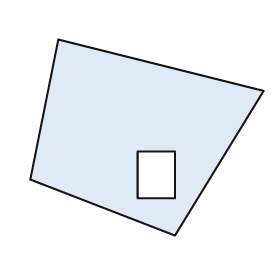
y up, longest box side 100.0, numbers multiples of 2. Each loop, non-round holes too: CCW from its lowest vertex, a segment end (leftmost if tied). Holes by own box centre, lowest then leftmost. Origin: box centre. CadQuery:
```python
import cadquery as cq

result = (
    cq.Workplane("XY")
    .moveTo(12.0, -42.0)
    .lineTo(50.0, 20.0)
    .lineTo(-38.0, 42.0)
    .lineTo(-50.0, -18.0)
    .close()
    .moveTo(-4.0, -26.0)
    .lineTo(12.0, -26.0)
    .lineTo(12.0, -6.0)
    .lineTo(-4.0, -6.0)
    .close()
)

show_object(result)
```